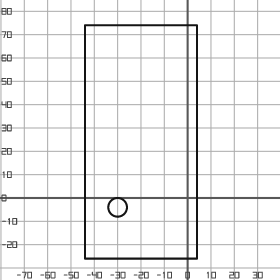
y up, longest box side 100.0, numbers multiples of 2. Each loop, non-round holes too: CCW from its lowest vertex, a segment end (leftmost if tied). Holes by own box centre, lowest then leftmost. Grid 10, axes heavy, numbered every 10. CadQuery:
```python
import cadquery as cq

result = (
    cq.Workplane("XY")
    .moveTo(-44.0, -26.0)
    .lineTo(4.0, -26.0)
    .lineTo(4.0, 74.0)
    .lineTo(-44.0, 74.0)
    .close()
    .moveTo(-30.0, -4.0)
    .circle(4.0)
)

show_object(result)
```